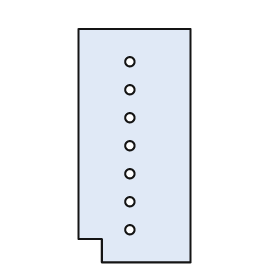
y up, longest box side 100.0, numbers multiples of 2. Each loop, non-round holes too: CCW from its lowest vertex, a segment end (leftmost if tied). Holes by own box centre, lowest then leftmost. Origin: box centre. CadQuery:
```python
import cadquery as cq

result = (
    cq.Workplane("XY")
    .moveTo(-14.0, -50.0)
    .lineTo(24.0, -50.0)
    .lineTo(24.0, 50.0)
    .lineTo(-24.0, 50.0)
    .lineTo(-24.0, -40.0)
    .lineTo(-14.0, -40.0)
    .close()
    .moveTo(-2.0, -36.0)
    .circle(2.0)
    .moveTo(-2.0, -24.0)
    .circle(2.0)
    .moveTo(-2.0, -12.0)
    .circle(2.0)
    .moveTo(-2.0, 0.0)
    .circle(2.0)
    .moveTo(-2.0, 12.0)
    .circle(2.0)
    .moveTo(-2.0, 24.0)
    .circle(2.0)
    .moveTo(-2.0, 36.0)
    .circle(2.0)
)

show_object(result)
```